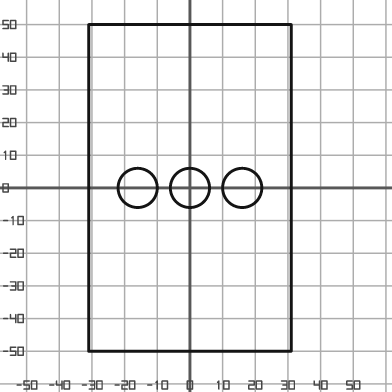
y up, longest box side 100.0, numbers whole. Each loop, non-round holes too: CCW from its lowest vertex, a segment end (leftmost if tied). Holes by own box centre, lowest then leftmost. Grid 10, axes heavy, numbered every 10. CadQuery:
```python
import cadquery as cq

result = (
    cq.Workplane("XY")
    .moveTo(-31.0, -50.0)
    .lineTo(31.0, -50.0)
    .lineTo(31.0, 50.0)
    .lineTo(-31.0, 50.0)
    .close()
    .moveTo(-16.0, 0.0)
    .circle(6.0)
    .moveTo(0.0, 0.0)
    .circle(6.0)
    .moveTo(16.0, 0.0)
    .circle(6.0)
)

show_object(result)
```